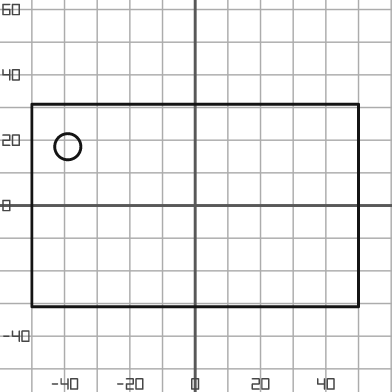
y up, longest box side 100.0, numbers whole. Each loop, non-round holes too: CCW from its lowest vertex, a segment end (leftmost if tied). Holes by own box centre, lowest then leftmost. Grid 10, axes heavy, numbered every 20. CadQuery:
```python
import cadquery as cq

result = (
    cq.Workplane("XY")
    .moveTo(-50.0, -31.0)
    .lineTo(50.0, -31.0)
    .lineTo(50.0, 31.0)
    .lineTo(-50.0, 31.0)
    .close()
    .moveTo(-39.0, 18.0)
    .circle(4.0)
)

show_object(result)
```